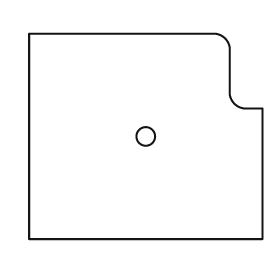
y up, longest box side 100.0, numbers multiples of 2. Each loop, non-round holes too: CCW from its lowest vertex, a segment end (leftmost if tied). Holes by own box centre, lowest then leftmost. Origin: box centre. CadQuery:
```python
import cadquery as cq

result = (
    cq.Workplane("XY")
    .moveTo(-50.0, -44.0)
    .lineTo(50.0, -44.0)
    .lineTo(50.0, 12.0)
    .lineTo(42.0, 12.0)
    .threePointArc((38.0, 14.0), (36.0, 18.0))
    .lineTo(36.0, 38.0)
    .threePointArc((34.0, 42.0), (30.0, 44.0))
    .lineTo(-50.0, 44.0)
    .close()
    .moveTo(0.0, 0.0)
    .circle(4.0)
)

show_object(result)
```